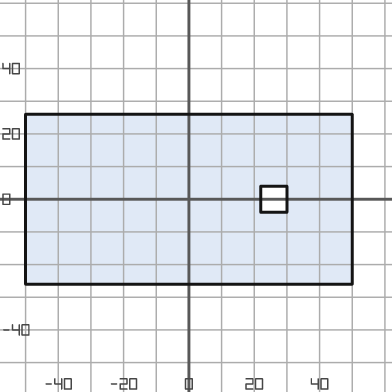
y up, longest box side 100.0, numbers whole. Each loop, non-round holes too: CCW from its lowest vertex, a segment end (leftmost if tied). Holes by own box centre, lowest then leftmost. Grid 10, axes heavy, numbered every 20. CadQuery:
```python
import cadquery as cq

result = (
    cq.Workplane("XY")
    .moveTo(-50.0, -26.0)
    .lineTo(50.0, -26.0)
    .lineTo(50.0, 26.0)
    .lineTo(-50.0, 26.0)
    .close()
    .moveTo(22.0, -4.0)
    .lineTo(30.0, -4.0)
    .lineTo(30.0, 4.0)
    .lineTo(22.0, 4.0)
    .close()
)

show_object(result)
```